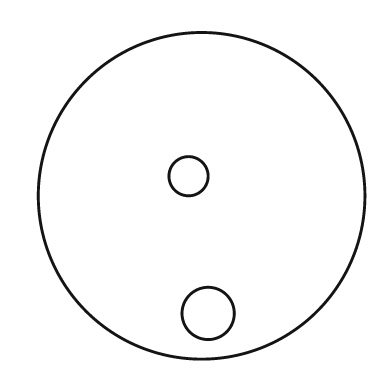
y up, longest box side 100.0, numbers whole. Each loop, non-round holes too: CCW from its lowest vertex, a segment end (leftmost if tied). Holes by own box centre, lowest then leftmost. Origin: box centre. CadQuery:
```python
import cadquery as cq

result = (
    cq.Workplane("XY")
    .moveTo(0.0, 0.0)
    .circle(50.0)
    .moveTo(2.0, -36.0)
    .circle(8.0)
    .moveTo(-4.0, 6.0)
    .circle(6.0)
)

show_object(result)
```